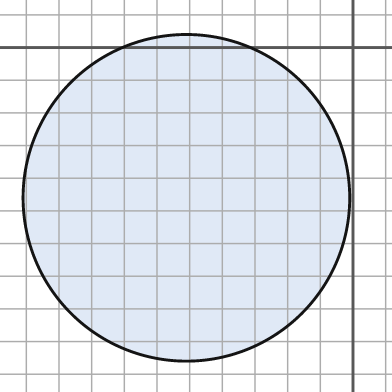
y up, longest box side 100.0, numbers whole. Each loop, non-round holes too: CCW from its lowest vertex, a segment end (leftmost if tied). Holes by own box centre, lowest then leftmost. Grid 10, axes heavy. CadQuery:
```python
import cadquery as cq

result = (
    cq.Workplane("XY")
    .moveTo(-51.0, -46.0)
    .circle(50.0)
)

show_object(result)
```